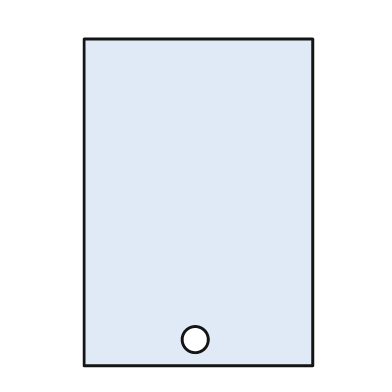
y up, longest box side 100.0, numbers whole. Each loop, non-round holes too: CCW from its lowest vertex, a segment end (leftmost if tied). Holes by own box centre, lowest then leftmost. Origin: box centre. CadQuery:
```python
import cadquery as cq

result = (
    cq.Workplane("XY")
    .moveTo(-35.0, -50.0)
    .lineTo(35.0, -50.0)
    .lineTo(35.0, 50.0)
    .lineTo(-35.0, 50.0)
    .close()
    .moveTo(-1.0, -42.0)
    .circle(4.0)
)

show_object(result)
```